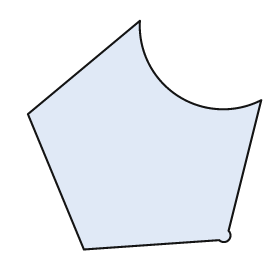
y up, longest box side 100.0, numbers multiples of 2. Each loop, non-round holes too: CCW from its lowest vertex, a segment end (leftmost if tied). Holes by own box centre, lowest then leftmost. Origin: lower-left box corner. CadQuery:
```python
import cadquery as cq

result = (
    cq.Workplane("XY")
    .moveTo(24.0, 0.0)
    .lineTo(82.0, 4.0)
    .threePointArc((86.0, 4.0), (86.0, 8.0))
    .lineTo(100.0, 64.0)
    .threePointArc((64.0, 66.0), (48.0, 98.0))
    .lineTo(0.0, 58.0)
    .close()
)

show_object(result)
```